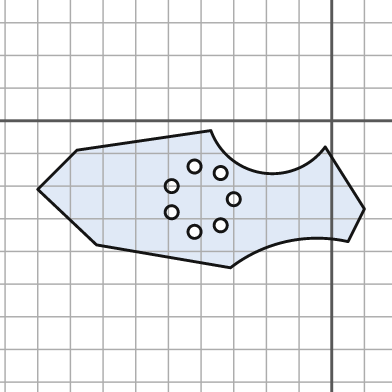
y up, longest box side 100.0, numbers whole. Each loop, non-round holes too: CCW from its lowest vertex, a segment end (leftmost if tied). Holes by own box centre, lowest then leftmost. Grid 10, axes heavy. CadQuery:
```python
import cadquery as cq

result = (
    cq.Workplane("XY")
    .moveTo(-31.0, -45.0)
    .threePointArc((-14.0, -37.0), (5.0, -37.0))
    .lineTo(10.0, -27.0)
    .lineTo(-2.0, -8.0)
    .threePointArc((-21.0, -16.0), (-37.0, -3.0))
    .lineTo(-78.0, -9.0)
    .lineTo(-90.0, -21.0)
    .lineTo(-72.0, -38.0)
    .close()
    .moveTo(-42.0, -34.0)
    .circle(2.0)
    .moveTo(-34.0, -32.0)
    .circle(2.0)
    .moveTo(-49.0, -28.0)
    .circle(2.0)
    .moveTo(-30.0, -24.0)
    .circle(2.0)
    .moveTo(-49.0, -20.0)
    .circle(2.0)
    .moveTo(-34.0, -16.0)
    .circle(2.0)
    .moveTo(-42.0, -14.0)
    .circle(2.0)
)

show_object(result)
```